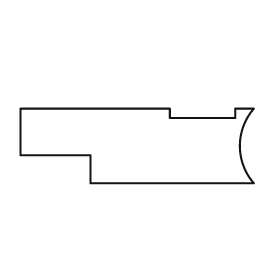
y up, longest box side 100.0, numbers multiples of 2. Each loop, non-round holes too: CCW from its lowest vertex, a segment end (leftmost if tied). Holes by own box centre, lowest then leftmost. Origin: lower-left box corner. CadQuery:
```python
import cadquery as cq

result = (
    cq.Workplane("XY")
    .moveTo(30.0, 0.0)
    .lineTo(100.0, 0.0)
    .threePointArc((94.0, 16.0), (100.0, 32.0))
    .lineTo(92.0, 32.0)
    .lineTo(92.0, 28.0)
    .lineTo(64.0, 28.0)
    .lineTo(64.0, 32.0)
    .lineTo(0.0, 32.0)
    .lineTo(0.0, 12.0)
    .lineTo(30.0, 12.0)
    .close()
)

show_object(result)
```